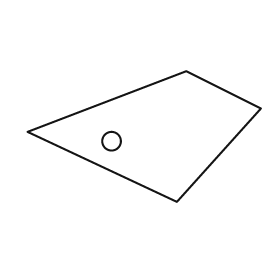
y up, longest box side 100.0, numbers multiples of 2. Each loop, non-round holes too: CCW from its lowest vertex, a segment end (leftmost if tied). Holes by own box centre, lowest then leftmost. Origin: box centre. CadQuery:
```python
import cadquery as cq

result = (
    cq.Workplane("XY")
    .moveTo(14.0, -28.0)
    .lineTo(50.0, 12.0)
    .lineTo(18.0, 28.0)
    .lineTo(-50.0, 2.0)
    .close()
    .moveTo(-14.0, -2.0)
    .circle(4.0)
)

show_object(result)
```